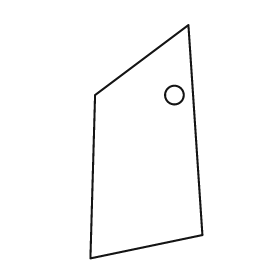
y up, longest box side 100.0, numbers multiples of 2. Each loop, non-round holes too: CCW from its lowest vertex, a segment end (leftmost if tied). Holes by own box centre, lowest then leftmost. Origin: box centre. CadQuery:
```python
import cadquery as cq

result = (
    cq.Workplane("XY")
    .moveTo(-24.0, -50.0)
    .lineTo(24.0, -40.0)
    .lineTo(18.0, 50.0)
    .lineTo(-22.0, 20.0)
    .close()
    .moveTo(12.0, 20.0)
    .circle(4.0)
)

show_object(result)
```